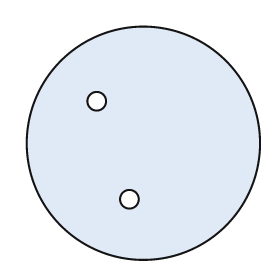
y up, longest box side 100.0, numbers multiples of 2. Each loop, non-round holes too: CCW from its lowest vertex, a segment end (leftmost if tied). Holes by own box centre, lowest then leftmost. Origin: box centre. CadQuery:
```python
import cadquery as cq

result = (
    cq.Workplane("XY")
    .moveTo(0.0, 0.0)
    .circle(50.0)
    .moveTo(-6.0, -24.0)
    .circle(4.0)
    .moveTo(-20.0, 18.0)
    .circle(4.0)
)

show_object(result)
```